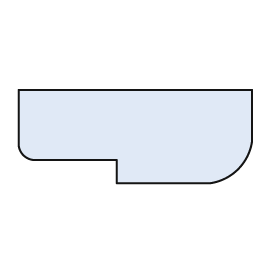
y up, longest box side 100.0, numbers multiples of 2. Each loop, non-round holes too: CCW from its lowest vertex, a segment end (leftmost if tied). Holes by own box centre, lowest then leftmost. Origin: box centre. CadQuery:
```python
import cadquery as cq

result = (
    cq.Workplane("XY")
    .moveTo(-8.0, -20.0)
    .lineTo(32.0, -20.0)
    .threePointArc((44.0, -14.0), (50.0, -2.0))
    .lineTo(50.0, 20.0)
    .lineTo(-50.0, 20.0)
    .lineTo(-50.0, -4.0)
    .threePointArc((-48.0, -8.0), (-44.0, -10.0))
    .lineTo(-8.0, -10.0)
    .close()
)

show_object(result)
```